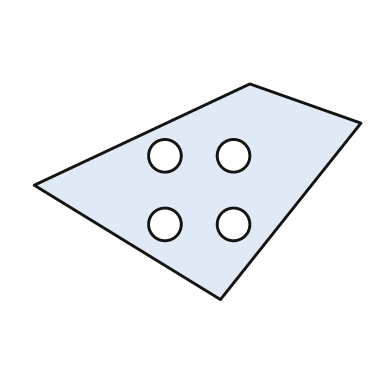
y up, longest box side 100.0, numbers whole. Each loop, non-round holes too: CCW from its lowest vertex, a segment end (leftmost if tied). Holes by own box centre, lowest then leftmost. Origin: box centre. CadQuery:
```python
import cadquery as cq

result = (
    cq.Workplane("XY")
    .moveTo(7.0, -33.0)
    .lineTo(50.0, 21.0)
    .lineTo(16.0, 33.0)
    .lineTo(-50.0, 2.0)
    .close()
    .moveTo(-10.0, -10.0)
    .circle(5.0)
    .moveTo(11.0, -10.0)
    .circle(5.0)
    .moveTo(-10.0, 11.0)
    .circle(5.0)
    .moveTo(11.0, 11.0)
    .circle(5.0)
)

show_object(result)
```